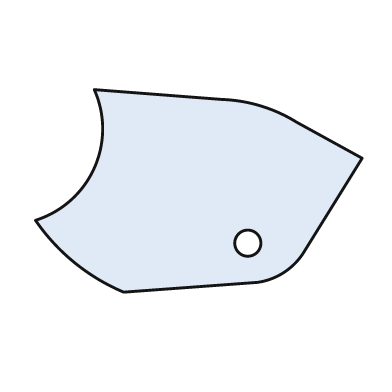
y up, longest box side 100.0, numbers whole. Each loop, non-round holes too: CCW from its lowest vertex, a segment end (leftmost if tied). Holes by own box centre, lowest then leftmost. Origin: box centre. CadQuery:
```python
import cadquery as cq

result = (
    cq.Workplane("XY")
    .moveTo(-23.0, -31.0)
    .lineTo(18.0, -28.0)
    .threePointArc((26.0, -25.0), (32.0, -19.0))
    .lineTo(50.0, 10.0)
    .lineTo(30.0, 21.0)
    .threePointArc((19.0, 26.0), (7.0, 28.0))
    .lineTo(-32.0, 31.0)
    .threePointArc((-32.0, 7.0), (-50.0, -9.0))
    .threePointArc((-38.0, -22.0), (-23.0, -31.0))
    .close()
    .moveTo(15.0, -16.0)
    .circle(4.0)
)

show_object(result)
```